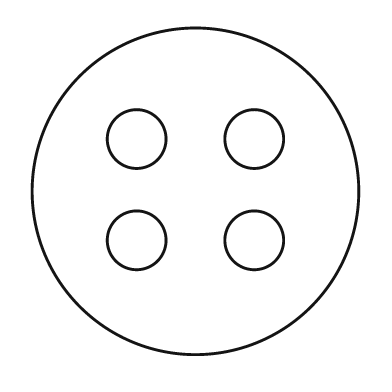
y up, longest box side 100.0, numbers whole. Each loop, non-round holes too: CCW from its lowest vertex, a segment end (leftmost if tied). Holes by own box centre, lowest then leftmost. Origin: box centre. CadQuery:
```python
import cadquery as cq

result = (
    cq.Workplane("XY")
    .moveTo(0.0, 0.0)
    .circle(50.0)
    .moveTo(-18.0, -15.0)
    .circle(9.0)
    .moveTo(18.0, -15.0)
    .circle(9.0)
    .moveTo(-18.0, 16.0)
    .circle(9.0)
    .moveTo(18.0, 16.0)
    .circle(9.0)
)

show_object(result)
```